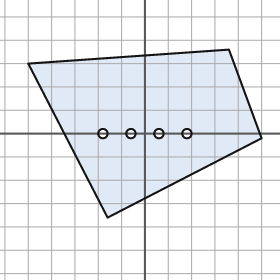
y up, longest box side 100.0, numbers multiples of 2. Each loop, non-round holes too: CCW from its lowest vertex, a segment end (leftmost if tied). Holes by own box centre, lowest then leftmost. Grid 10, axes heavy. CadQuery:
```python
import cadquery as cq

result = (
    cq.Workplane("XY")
    .moveTo(-16.0, -36.0)
    .lineTo(50.0, -2.0)
    .lineTo(36.0, 36.0)
    .lineTo(-50.0, 30.0)
    .close()
    .moveTo(-18.0, 0.0)
    .circle(2.0)
    .moveTo(-6.0, 0.0)
    .circle(2.0)
    .moveTo(6.0, 0.0)
    .circle(2.0)
    .moveTo(18.0, 0.0)
    .circle(2.0)
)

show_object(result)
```